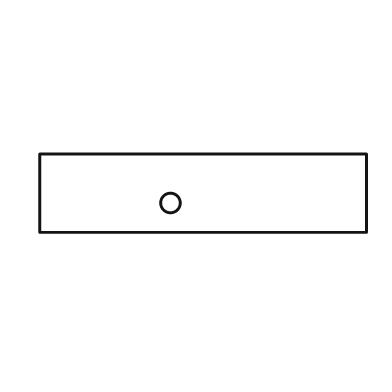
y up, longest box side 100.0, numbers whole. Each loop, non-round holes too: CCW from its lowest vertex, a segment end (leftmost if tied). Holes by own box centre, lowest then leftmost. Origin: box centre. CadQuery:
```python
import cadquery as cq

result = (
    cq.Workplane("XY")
    .moveTo(-50.0, -12.0)
    .lineTo(50.0, -12.0)
    .lineTo(50.0, 12.0)
    .lineTo(-50.0, 12.0)
    .close()
    .moveTo(-10.0, -3.0)
    .circle(3.0)
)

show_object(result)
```